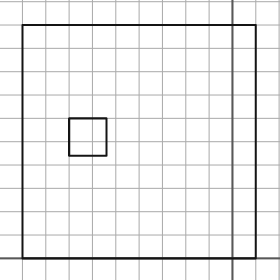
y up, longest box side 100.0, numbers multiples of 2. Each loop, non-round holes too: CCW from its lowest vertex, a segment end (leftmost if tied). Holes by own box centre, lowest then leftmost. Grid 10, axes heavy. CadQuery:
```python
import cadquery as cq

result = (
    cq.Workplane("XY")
    .moveTo(-90.0, 0.0)
    .lineTo(10.0, 0.0)
    .lineTo(10.0, 100.0)
    .lineTo(-90.0, 100.0)
    .close()
    .moveTo(-70.0, 44.0)
    .lineTo(-54.0, 44.0)
    .lineTo(-54.0, 60.0)
    .lineTo(-70.0, 60.0)
    .close()
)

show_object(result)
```